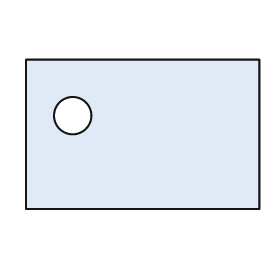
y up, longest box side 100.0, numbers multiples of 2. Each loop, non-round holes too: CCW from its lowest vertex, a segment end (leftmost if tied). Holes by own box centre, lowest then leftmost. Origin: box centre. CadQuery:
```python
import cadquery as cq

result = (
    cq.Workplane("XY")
    .moveTo(-50.0, -32.0)
    .lineTo(50.0, -32.0)
    .lineTo(50.0, 32.0)
    .lineTo(-50.0, 32.0)
    .close()
    .moveTo(-30.0, 8.0)
    .circle(8.0)
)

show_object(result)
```